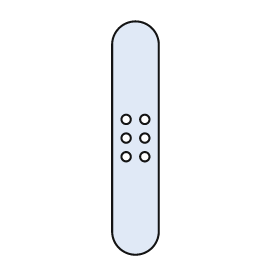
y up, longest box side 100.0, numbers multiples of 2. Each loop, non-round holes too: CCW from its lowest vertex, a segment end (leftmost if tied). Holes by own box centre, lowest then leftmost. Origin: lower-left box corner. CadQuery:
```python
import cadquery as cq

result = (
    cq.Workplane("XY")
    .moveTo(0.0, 10.0)
    .threePointArc((10.0, 0.0), (20.0, 10.0))
    .lineTo(20.0, 90.0)
    .threePointArc((10.0, 100.0), (0.0, 90.0))
    .close()
    .moveTo(6.0, 42.0)
    .circle(2.0)
    .moveTo(14.0, 42.0)
    .circle(2.0)
    .moveTo(6.0, 50.0)
    .circle(2.0)
    .moveTo(14.0, 50.0)
    .circle(2.0)
    .moveTo(6.0, 58.0)
    .circle(2.0)
    .moveTo(14.0, 58.0)
    .circle(2.0)
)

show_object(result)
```